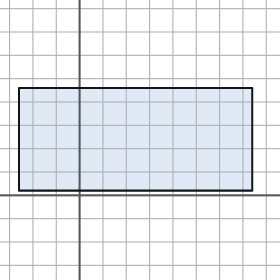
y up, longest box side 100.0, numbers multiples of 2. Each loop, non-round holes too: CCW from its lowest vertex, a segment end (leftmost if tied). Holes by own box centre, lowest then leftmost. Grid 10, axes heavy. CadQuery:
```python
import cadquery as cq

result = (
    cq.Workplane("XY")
    .moveTo(-26.0, 2.0)
    .lineTo(74.0, 2.0)
    .lineTo(74.0, 46.0)
    .lineTo(-26.0, 46.0)
    .close()
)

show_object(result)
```